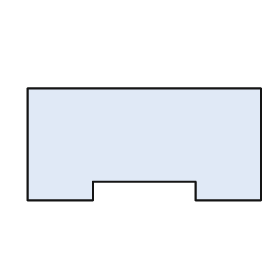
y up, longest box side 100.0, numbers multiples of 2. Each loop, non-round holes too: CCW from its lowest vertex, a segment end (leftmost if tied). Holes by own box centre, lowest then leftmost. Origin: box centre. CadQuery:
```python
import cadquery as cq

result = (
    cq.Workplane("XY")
    .moveTo(-50.0, -24.0)
    .lineTo(-22.0, -24.0)
    .lineTo(-22.0, -16.0)
    .lineTo(22.0, -16.0)
    .lineTo(22.0, -24.0)
    .lineTo(50.0, -24.0)
    .lineTo(50.0, 24.0)
    .lineTo(-50.0, 24.0)
    .close()
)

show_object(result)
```